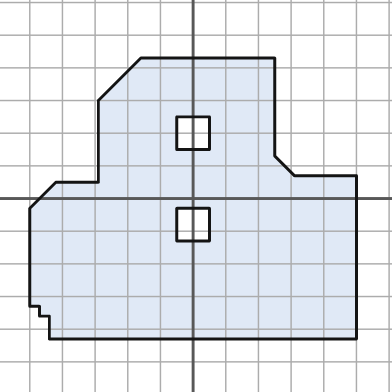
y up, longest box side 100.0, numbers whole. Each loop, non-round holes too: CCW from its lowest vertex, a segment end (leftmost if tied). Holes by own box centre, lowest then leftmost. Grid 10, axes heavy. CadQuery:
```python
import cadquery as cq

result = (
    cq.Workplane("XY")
    .moveTo(-44.0, -43.0)
    .lineTo(50.0, -43.0)
    .lineTo(50.0, 7.0)
    .lineTo(31.0, 7.0)
    .lineTo(25.0, 13.0)
    .lineTo(25.0, 43.0)
    .lineTo(-16.0, 43.0)
    .lineTo(-29.0, 30.0)
    .lineTo(-29.0, 5.0)
    .lineTo(-42.0, 5.0)
    .lineTo(-50.0, -3.0)
    .lineTo(-50.0, -33.0)
    .lineTo(-47.0, -33.0)
    .lineTo(-47.0, -36.0)
    .lineTo(-44.0, -36.0)
    .close()
    .moveTo(-5.0, -13.0)
    .lineTo(5.0, -13.0)
    .lineTo(5.0, -3.0)
    .lineTo(-5.0, -3.0)
    .close()
    .moveTo(-5.0, 15.0)
    .lineTo(5.0, 15.0)
    .lineTo(5.0, 25.0)
    .lineTo(-5.0, 25.0)
    .close()
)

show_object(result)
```